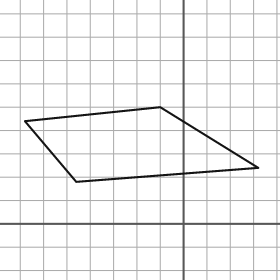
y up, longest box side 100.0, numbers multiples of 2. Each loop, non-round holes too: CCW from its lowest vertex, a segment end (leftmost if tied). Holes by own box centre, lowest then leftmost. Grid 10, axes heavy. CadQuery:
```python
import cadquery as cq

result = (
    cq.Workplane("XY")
    .moveTo(-46.0, 18.0)
    .lineTo(32.0, 24.0)
    .lineTo(-10.0, 50.0)
    .lineTo(-68.0, 44.0)
    .close()
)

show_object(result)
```